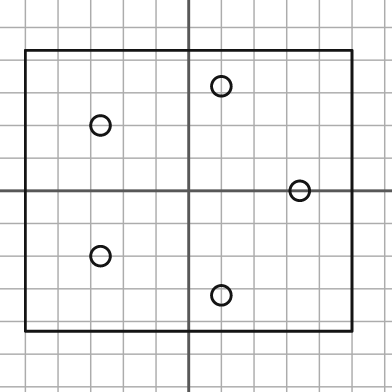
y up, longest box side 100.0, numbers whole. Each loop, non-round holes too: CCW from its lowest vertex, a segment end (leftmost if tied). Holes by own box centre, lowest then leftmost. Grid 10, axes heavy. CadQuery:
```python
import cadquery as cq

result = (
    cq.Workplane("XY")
    .moveTo(-50.0, -43.0)
    .lineTo(50.0, -43.0)
    .lineTo(50.0, 43.0)
    .lineTo(-50.0, 43.0)
    .close()
    .moveTo(10.0, -32.0)
    .circle(3.0)
    .moveTo(-27.0, -20.0)
    .circle(3.0)
    .moveTo(34.0, 0.0)
    .circle(3.0)
    .moveTo(-27.0, 20.0)
    .circle(3.0)
    .moveTo(10.0, 32.0)
    .circle(3.0)
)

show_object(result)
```